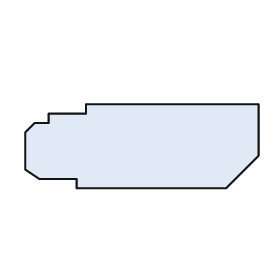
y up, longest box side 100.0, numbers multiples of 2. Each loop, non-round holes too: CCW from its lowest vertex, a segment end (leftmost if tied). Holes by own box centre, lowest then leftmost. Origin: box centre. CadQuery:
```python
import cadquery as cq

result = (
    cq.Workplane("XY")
    .moveTo(-28.0, -18.0)
    .lineTo(36.0, -18.0)
    .lineTo(50.0, -4.0)
    .lineTo(50.0, 18.0)
    .lineTo(-24.0, 18.0)
    .lineTo(-24.0, 14.0)
    .lineTo(-40.0, 14.0)
    .lineTo(-40.0, 10.0)
    .lineTo(-46.0, 10.0)
    .lineTo(-50.0, 6.0)
    .lineTo(-50.0, -10.0)
    .lineTo(-44.0, -14.0)
    .lineTo(-28.0, -14.0)
    .close()
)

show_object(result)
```